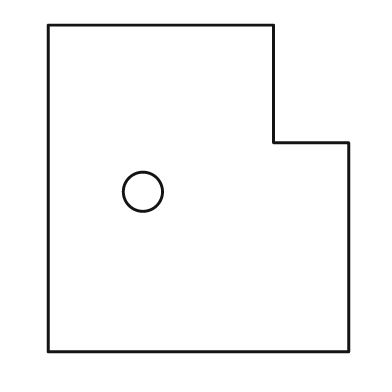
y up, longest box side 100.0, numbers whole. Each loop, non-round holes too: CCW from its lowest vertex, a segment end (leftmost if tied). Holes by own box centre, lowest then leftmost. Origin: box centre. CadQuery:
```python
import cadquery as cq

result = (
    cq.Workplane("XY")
    .moveTo(-46.0, -50.0)
    .lineTo(46.0, -50.0)
    .lineTo(46.0, 14.0)
    .lineTo(23.0, 14.0)
    .lineTo(23.0, 50.0)
    .lineTo(-46.0, 50.0)
    .close()
    .moveTo(-17.0, -1.0)
    .circle(6.0)
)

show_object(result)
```